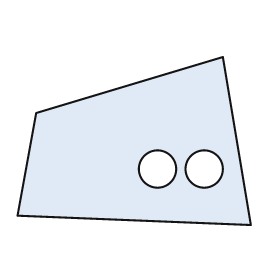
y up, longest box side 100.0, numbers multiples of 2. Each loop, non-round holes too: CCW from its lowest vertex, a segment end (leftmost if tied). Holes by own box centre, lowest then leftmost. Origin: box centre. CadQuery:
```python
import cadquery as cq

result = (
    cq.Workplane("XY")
    .moveTo(50.0, -36.0)
    .lineTo(38.0, 36.0)
    .lineTo(-42.0, 12.0)
    .lineTo(-50.0, -32.0)
    .close()
    .moveTo(10.0, -12.0)
    .circle(8.0)
    .moveTo(30.0, -12.0)
    .circle(8.0)
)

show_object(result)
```